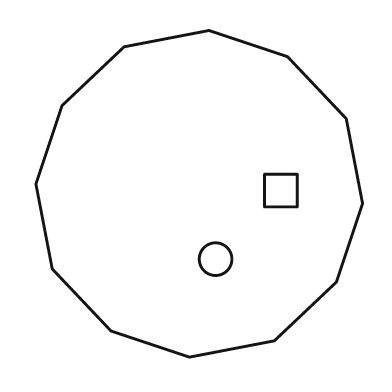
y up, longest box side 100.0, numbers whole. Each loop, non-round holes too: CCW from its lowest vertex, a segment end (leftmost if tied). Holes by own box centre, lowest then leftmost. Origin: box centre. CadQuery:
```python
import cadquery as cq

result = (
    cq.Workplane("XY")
    .moveTo(-3.0, -50.0)
    .lineTo(23.0, -45.0)
    .lineTo(42.0, -27.0)
    .lineTo(50.0, -3.0)
    .lineTo(45.0, 23.0)
    .lineTo(27.0, 42.0)
    .lineTo(3.0, 50.0)
    .lineTo(-23.0, 45.0)
    .lineTo(-42.0, 27.0)
    .lineTo(-50.0, 3.0)
    .lineTo(-45.0, -23.0)
    .lineTo(-27.0, -42.0)
    .close()
    .moveTo(5.0, -20.0)
    .circle(5.0)
    .moveTo(20.0, -4.0)
    .lineTo(30.0, -4.0)
    .lineTo(30.0, 6.0)
    .lineTo(20.0, 6.0)
    .close()
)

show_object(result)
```